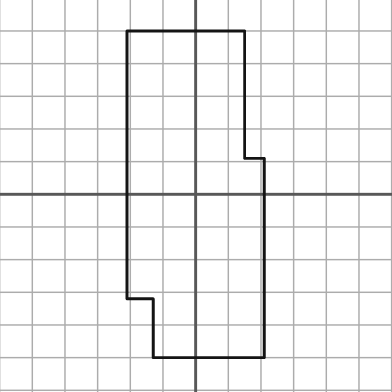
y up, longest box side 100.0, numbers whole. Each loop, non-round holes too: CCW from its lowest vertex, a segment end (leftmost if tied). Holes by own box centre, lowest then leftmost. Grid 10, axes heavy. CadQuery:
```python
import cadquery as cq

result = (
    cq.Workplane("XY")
    .moveTo(-13.0, -50.0)
    .lineTo(21.0, -50.0)
    .lineTo(21.0, 11.0)
    .lineTo(15.0, 11.0)
    .lineTo(15.0, 50.0)
    .lineTo(-21.0, 50.0)
    .lineTo(-21.0, -32.0)
    .lineTo(-13.0, -32.0)
    .close()
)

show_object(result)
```